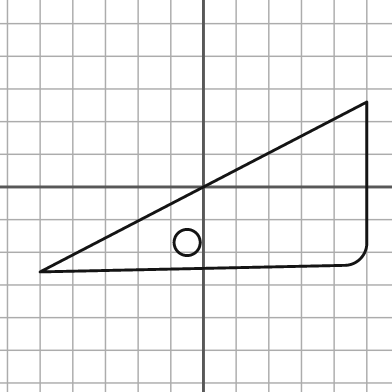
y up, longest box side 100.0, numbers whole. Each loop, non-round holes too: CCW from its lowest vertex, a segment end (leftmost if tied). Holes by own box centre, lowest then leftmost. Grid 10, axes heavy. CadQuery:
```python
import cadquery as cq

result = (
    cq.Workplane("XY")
    .moveTo(-50.0, -26.0)
    .lineTo(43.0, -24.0)
    .threePointArc((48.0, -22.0), (50.0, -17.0))
    .lineTo(50.0, 26.0)
    .close()
    .moveTo(-5.0, -17.0)
    .circle(4.0)
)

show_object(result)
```